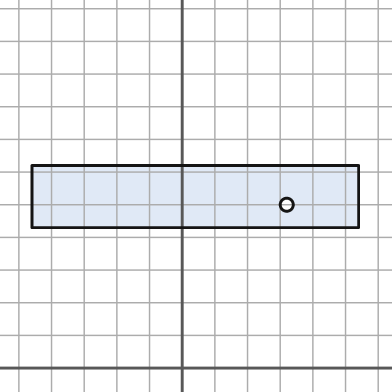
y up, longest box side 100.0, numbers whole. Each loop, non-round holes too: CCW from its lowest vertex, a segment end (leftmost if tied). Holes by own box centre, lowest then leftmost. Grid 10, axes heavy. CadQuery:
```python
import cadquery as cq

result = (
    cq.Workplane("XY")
    .moveTo(-46.0, 43.0)
    .lineTo(54.0, 43.0)
    .lineTo(54.0, 62.0)
    .lineTo(-46.0, 62.0)
    .close()
    .moveTo(32.0, 50.0)
    .circle(2.0)
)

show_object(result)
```